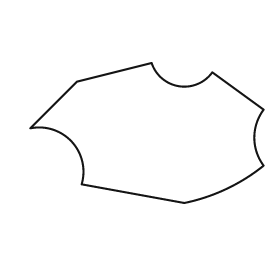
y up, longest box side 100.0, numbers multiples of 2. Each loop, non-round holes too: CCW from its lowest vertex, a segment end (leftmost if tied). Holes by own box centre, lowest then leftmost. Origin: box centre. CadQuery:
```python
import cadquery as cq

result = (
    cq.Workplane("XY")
    .moveTo(16.0, -30.0)
    .threePointArc((34.0, -24.0), (50.0, -14.0))
    .threePointArc((46.0, -2.0), (50.0, 10.0))
    .lineTo(28.0, 26.0)
    .threePointArc((14.0, 20.0), (2.0, 30.0))
    .lineTo(-30.0, 22.0)
    .lineTo(-50.0, 2.0)
    .threePointArc((-32.0, -4.0), (-28.0, -22.0))
    .close()
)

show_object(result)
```